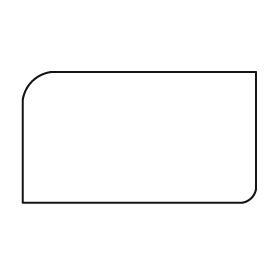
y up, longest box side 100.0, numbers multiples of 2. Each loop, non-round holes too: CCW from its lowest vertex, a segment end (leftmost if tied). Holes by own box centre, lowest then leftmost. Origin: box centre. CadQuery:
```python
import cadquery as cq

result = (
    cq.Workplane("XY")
    .moveTo(-50.0, -28.0)
    .lineTo(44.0, -28.0)
    .threePointArc((48.0, -26.0), (50.0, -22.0))
    .lineTo(50.0, 28.0)
    .lineTo(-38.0, 28.0)
    .threePointArc((-46.0, 24.0), (-50.0, 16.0))
    .close()
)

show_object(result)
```